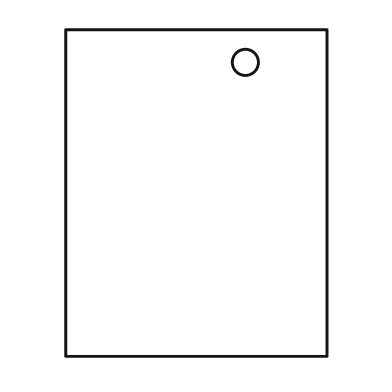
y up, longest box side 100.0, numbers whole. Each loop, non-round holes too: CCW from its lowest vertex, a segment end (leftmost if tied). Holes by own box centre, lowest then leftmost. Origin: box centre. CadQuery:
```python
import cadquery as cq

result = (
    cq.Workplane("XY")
    .moveTo(-40.0, -50.0)
    .lineTo(40.0, -50.0)
    .lineTo(40.0, 50.0)
    .lineTo(-40.0, 50.0)
    .close()
    .moveTo(15.0, 40.0)
    .circle(4.0)
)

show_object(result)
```